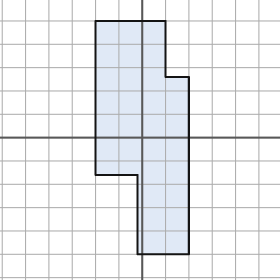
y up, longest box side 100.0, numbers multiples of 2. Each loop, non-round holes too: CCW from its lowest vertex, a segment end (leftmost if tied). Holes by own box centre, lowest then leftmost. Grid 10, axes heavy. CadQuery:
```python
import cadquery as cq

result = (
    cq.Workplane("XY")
    .moveTo(-2.0, -50.0)
    .lineTo(20.0, -50.0)
    .lineTo(20.0, 26.0)
    .lineTo(10.0, 26.0)
    .lineTo(10.0, 50.0)
    .lineTo(-20.0, 50.0)
    .lineTo(-20.0, -16.0)
    .lineTo(-2.0, -16.0)
    .close()
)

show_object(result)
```